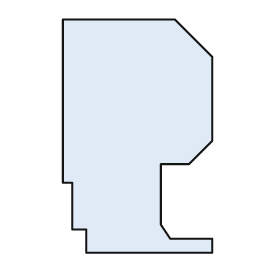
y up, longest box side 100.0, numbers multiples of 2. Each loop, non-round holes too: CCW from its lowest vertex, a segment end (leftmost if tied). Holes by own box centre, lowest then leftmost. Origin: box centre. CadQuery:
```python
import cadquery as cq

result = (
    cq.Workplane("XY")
    .moveTo(-22.0, -50.0)
    .lineTo(32.0, -50.0)
    .lineTo(32.0, -44.0)
    .lineTo(14.0, -44.0)
    .lineTo(10.0, -38.0)
    .lineTo(10.0, -12.0)
    .lineTo(22.0, -12.0)
    .lineTo(32.0, -2.0)
    .lineTo(32.0, 34.0)
    .lineTo(16.0, 50.0)
    .lineTo(-32.0, 50.0)
    .lineTo(-32.0, -20.0)
    .lineTo(-28.0, -20.0)
    .lineTo(-28.0, -40.0)
    .lineTo(-22.0, -40.0)
    .close()
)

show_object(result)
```